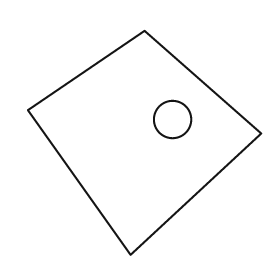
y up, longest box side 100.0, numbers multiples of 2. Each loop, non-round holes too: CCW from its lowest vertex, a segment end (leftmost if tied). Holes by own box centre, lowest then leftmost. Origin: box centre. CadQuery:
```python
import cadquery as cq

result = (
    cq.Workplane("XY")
    .moveTo(-6.0, -48.0)
    .lineTo(50.0, 4.0)
    .lineTo(0.0, 48.0)
    .lineTo(-50.0, 14.0)
    .close()
    .moveTo(12.0, 10.0)
    .circle(8.0)
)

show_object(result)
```